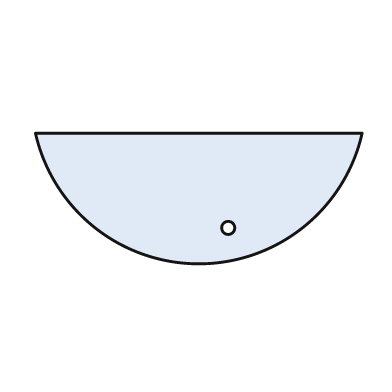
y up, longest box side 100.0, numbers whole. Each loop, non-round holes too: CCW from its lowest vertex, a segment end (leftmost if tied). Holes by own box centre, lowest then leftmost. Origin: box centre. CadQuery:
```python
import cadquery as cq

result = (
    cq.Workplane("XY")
    .moveTo(-50.0, 20.0)
    .threePointArc((0.0, -20.0), (50.0, 20.0))
    .close()
    .moveTo(9.0, -9.0)
    .circle(2.0)
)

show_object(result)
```